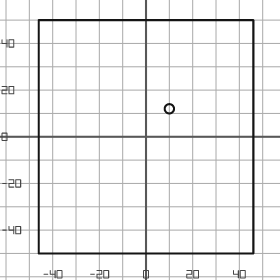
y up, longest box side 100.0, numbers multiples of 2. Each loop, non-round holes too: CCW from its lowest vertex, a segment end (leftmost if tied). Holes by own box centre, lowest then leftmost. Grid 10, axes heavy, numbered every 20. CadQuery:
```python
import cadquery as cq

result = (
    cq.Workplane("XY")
    .moveTo(-46.0, -50.0)
    .lineTo(46.0, -50.0)
    .lineTo(46.0, 50.0)
    .lineTo(-46.0, 50.0)
    .close()
    .moveTo(10.0, 12.0)
    .circle(2.0)
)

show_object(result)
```